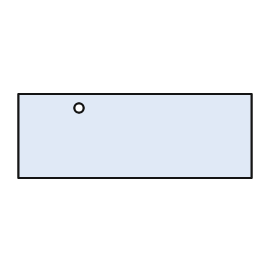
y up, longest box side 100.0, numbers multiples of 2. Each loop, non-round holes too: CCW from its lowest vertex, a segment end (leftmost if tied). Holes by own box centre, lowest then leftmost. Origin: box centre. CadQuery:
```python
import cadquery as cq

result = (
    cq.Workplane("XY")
    .moveTo(-50.0, -18.0)
    .lineTo(50.0, -18.0)
    .lineTo(50.0, 18.0)
    .lineTo(-50.0, 18.0)
    .close()
    .moveTo(-24.0, 12.0)
    .circle(2.0)
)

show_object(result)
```